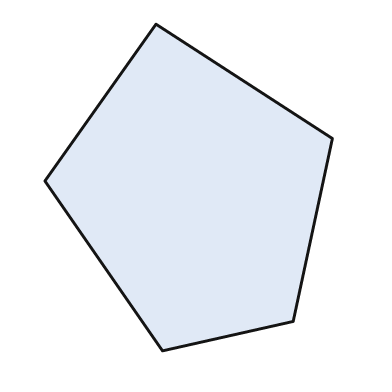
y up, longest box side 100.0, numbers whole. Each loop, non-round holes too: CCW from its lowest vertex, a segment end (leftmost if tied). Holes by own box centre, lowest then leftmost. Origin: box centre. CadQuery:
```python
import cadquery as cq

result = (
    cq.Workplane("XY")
    .moveTo(-8.0, -50.0)
    .lineTo(32.0, -41.0)
    .lineTo(44.0, 15.0)
    .lineTo(-10.0, 50.0)
    .lineTo(-44.0, 2.0)
    .close()
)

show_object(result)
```